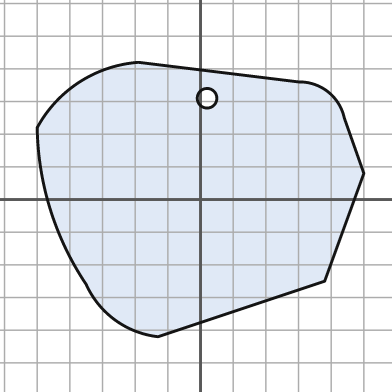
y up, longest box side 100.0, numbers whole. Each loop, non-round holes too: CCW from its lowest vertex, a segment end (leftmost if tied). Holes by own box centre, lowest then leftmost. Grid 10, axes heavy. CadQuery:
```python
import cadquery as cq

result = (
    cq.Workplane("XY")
    .moveTo(-13.0, -42.0)
    .lineTo(38.0, -25.0)
    .lineTo(50.0, 8.0)
    .lineTo(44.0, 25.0)
    .threePointArc((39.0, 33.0), (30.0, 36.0))
    .lineTo(-19.0, 42.0)
    .threePointArc((-37.0, 36.0), (-50.0, 22.0))
    .threePointArc((-46.0, -3.0), (-35.0, -26.0))
    .threePointArc((-26.0, -37.0), (-13.0, -42.0))
    .close()
    .moveTo(2.0, 31.0)
    .circle(3.0)
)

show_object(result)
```